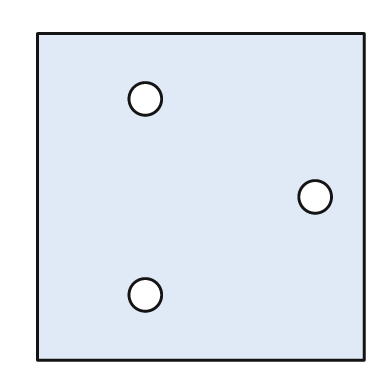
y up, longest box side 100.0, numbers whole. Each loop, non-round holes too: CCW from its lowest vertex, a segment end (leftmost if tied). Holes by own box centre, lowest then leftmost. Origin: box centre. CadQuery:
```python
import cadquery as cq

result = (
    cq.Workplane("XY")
    .moveTo(-50.0, -50.0)
    .lineTo(50.0, -50.0)
    .lineTo(50.0, 50.0)
    .lineTo(-50.0, 50.0)
    .close()
    .moveTo(-17.0, -30.0)
    .circle(5.0)
    .moveTo(35.0, 0.0)
    .circle(5.0)
    .moveTo(-17.0, 30.0)
    .circle(5.0)
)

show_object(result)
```